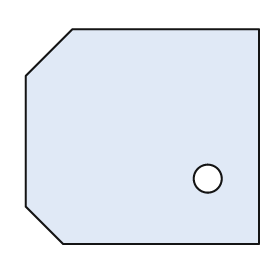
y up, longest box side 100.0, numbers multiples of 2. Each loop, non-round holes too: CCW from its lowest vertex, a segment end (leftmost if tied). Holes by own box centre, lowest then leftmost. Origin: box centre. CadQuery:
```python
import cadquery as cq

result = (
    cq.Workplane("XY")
    .moveTo(-34.0, -46.0)
    .lineTo(50.0, -46.0)
    .lineTo(50.0, 46.0)
    .lineTo(-30.0, 46.0)
    .lineTo(-50.0, 26.0)
    .lineTo(-50.0, -30.0)
    .close()
    .moveTo(28.0, -18.0)
    .circle(6.0)
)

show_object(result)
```